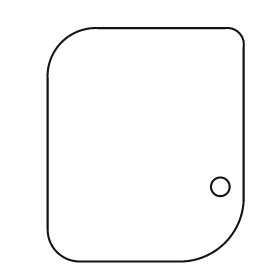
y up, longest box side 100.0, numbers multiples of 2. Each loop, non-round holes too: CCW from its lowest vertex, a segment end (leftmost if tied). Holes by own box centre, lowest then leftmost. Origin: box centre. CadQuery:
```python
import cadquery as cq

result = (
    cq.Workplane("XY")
    .moveTo(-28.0, -50.0)
    .lineTo(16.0, -50.0)
    .threePointArc((34.0, -42.0), (42.0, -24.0))
    .lineTo(42.0, 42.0)
    .threePointArc((40.0, 48.0), (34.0, 50.0))
    .lineTo(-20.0, 50.0)
    .threePointArc((-36.0, 44.0), (-42.0, 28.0))
    .lineTo(-42.0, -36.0)
    .threePointArc((-38.0, -46.0), (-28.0, -50.0))
    .close()
    .moveTo(32.0, -18.0)
    .circle(4.0)
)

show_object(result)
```